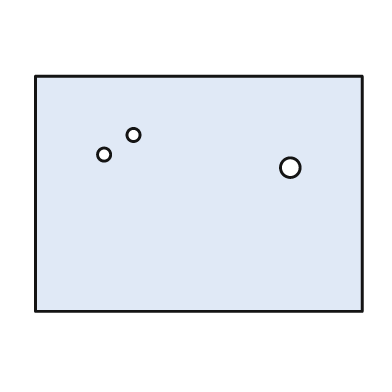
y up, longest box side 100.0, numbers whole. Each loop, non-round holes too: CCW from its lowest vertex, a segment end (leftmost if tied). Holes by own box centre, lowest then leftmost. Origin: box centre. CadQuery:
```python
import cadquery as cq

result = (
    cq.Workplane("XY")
    .moveTo(-50.0, -36.0)
    .lineTo(50.0, -36.0)
    .lineTo(50.0, 36.0)
    .lineTo(-50.0, 36.0)
    .close()
    .moveTo(28.0, 8.0)
    .circle(3.0)
    .moveTo(-29.0, 12.0)
    .circle(2.0)
    .moveTo(-20.0, 18.0)
    .circle(2.0)
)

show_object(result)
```